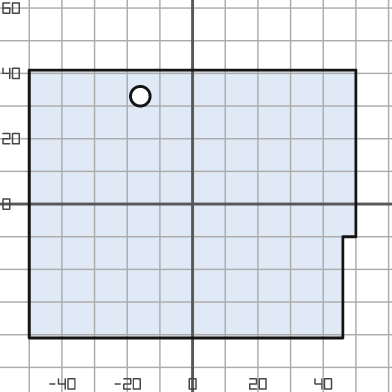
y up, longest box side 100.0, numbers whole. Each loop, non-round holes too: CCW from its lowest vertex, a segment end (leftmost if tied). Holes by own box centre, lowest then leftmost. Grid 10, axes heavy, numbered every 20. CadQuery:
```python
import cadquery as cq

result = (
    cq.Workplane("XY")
    .moveTo(-50.0, -41.0)
    .lineTo(46.0, -41.0)
    .lineTo(46.0, -10.0)
    .lineTo(50.0, -10.0)
    .lineTo(50.0, 41.0)
    .lineTo(-50.0, 41.0)
    .close()
    .moveTo(-16.0, 33.0)
    .circle(3.0)
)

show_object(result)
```